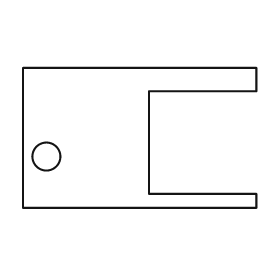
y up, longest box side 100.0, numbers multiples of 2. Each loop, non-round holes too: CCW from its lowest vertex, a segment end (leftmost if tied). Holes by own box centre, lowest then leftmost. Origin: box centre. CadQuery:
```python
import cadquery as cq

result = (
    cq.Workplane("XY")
    .moveTo(-50.0, -30.0)
    .lineTo(50.0, -30.0)
    .lineTo(50.0, -24.0)
    .lineTo(4.0, -24.0)
    .lineTo(4.0, 20.0)
    .lineTo(50.0, 20.0)
    .lineTo(50.0, 30.0)
    .lineTo(-50.0, 30.0)
    .close()
    .moveTo(-40.0, -8.0)
    .circle(6.0)
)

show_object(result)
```